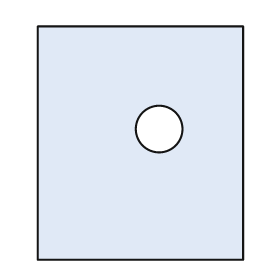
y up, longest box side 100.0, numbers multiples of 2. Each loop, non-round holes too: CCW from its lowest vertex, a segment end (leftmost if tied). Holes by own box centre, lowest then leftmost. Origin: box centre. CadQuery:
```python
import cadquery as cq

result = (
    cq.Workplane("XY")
    .moveTo(-44.0, -50.0)
    .lineTo(44.0, -50.0)
    .lineTo(44.0, 50.0)
    .lineTo(-44.0, 50.0)
    .close()
    .moveTo(8.0, 6.0)
    .circle(10.0)
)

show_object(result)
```